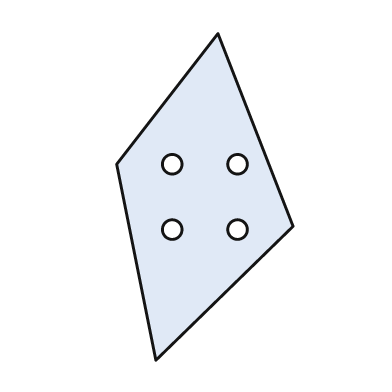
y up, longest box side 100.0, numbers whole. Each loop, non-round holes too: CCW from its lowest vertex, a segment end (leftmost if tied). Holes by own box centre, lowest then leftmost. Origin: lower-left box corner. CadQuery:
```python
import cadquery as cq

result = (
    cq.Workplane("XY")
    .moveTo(12.0, 0.0)
    .lineTo(54.0, 41.0)
    .lineTo(31.0, 100.0)
    .lineTo(0.0, 60.0)
    .close()
    .moveTo(17.0, 40.0)
    .circle(3.0)
    .moveTo(37.0, 40.0)
    .circle(3.0)
    .moveTo(17.0, 60.0)
    .circle(3.0)
    .moveTo(37.0, 60.0)
    .circle(3.0)
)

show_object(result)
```